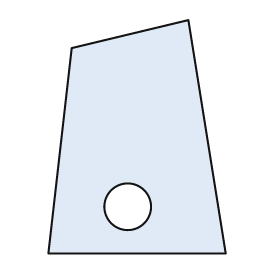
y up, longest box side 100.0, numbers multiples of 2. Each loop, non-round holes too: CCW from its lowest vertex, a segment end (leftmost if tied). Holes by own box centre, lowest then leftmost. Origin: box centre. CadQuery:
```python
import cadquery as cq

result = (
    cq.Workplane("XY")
    .moveTo(-38.0, -50.0)
    .lineTo(38.0, -50.0)
    .lineTo(22.0, 50.0)
    .lineTo(-28.0, 38.0)
    .close()
    .moveTo(-4.0, -30.0)
    .circle(10.0)
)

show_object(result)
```